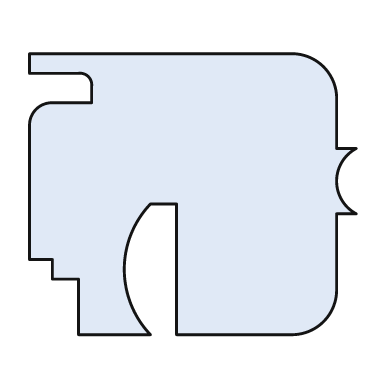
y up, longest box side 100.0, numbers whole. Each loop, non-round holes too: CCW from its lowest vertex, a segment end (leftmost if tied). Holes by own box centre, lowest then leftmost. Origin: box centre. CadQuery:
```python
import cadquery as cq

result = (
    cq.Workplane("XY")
    .moveTo(-35.0, -43.0)
    .lineTo(-13.0, -43.0)
    .threePointArc((-21.0, -23.0), (-13.0, -3.0))
    .lineTo(-5.0, -3.0)
    .lineTo(-5.0, -43.0)
    .lineTo(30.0, -43.0)
    .threePointArc((40.0, -39.0), (44.0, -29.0))
    .lineTo(44.0, -6.0)
    .lineTo(50.0, -6.0)
    .threePointArc((44.0, 4.0), (50.0, 14.0))
    .lineTo(44.0, 14.0)
    .lineTo(44.0, 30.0)
    .threePointArc((40.0, 39.0), (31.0, 43.0))
    .lineTo(-50.0, 43.0)
    .lineTo(-50.0, 37.0)
    .lineTo(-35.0, 37.0)
    .threePointArc((-32.0, 36.0), (-31.0, 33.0))
    .lineTo(-31.0, 28.0)
    .lineTo(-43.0, 28.0)
    .threePointArc((-48.0, 26.0), (-50.0, 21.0))
    .lineTo(-50.0, -20.0)
    .lineTo(-43.0, -20.0)
    .lineTo(-43.0, -26.0)
    .lineTo(-35.0, -26.0)
    .close()
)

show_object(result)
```